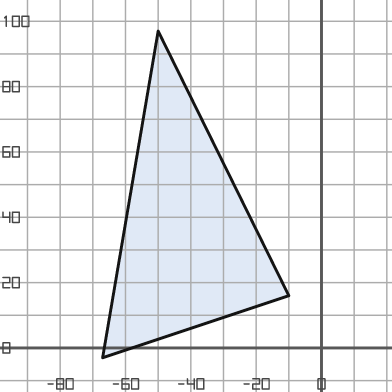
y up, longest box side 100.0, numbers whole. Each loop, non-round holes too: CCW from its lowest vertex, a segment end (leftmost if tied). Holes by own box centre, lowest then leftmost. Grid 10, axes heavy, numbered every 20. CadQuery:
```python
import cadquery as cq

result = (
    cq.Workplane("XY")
    .moveTo(-67.0, -3.0)
    .lineTo(-10.0, 16.0)
    .lineTo(-50.0, 97.0)
    .close()
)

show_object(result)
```